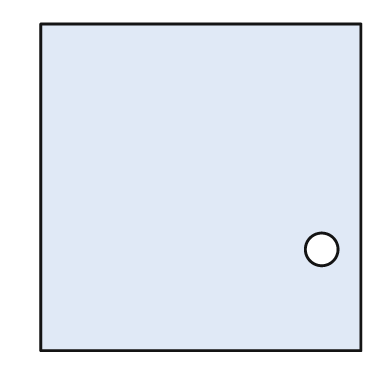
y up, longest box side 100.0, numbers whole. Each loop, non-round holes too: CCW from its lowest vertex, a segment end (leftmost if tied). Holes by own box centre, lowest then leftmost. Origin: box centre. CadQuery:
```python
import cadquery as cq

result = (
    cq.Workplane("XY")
    .moveTo(-49.0, -50.0)
    .lineTo(49.0, -50.0)
    .lineTo(49.0, 50.0)
    .lineTo(-49.0, 50.0)
    .close()
    .moveTo(37.0, -19.0)
    .circle(5.0)
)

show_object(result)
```